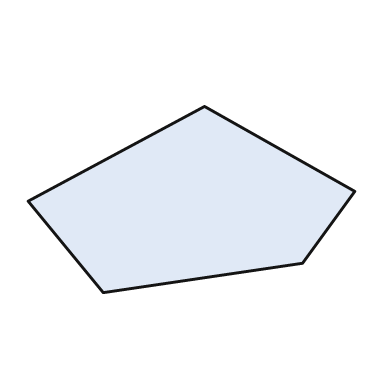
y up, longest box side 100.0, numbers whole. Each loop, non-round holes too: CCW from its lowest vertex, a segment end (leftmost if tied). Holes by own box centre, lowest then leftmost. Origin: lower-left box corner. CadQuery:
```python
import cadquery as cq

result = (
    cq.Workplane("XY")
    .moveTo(23.0, 0.0)
    .lineTo(84.0, 9.0)
    .lineTo(100.0, 31.0)
    .lineTo(54.0, 57.0)
    .lineTo(0.0, 28.0)
    .close()
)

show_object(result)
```